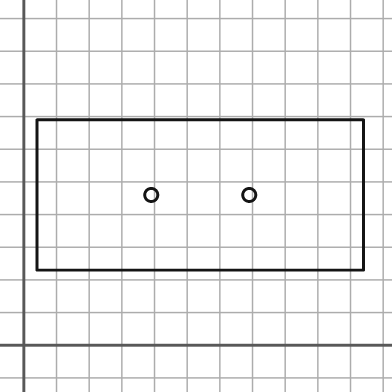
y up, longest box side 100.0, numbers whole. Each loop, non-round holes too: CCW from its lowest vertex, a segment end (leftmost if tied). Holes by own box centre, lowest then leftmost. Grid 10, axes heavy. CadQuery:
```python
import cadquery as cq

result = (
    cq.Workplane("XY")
    .moveTo(4.0, 23.0)
    .lineTo(104.0, 23.0)
    .lineTo(104.0, 69.0)
    .lineTo(4.0, 69.0)
    .close()
    .moveTo(39.0, 46.0)
    .circle(2.0)
    .moveTo(69.0, 46.0)
    .circle(2.0)
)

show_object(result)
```